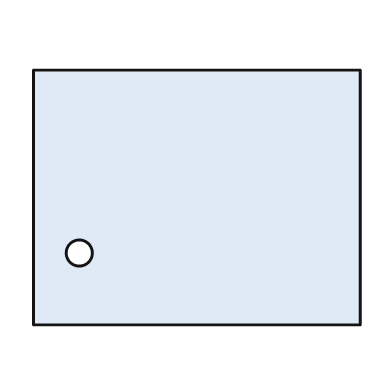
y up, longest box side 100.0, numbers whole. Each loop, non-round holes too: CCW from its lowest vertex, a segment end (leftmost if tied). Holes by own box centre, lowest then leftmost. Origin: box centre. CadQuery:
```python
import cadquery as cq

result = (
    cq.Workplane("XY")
    .moveTo(-50.0, -39.0)
    .lineTo(50.0, -39.0)
    .lineTo(50.0, 39.0)
    .lineTo(-50.0, 39.0)
    .close()
    .moveTo(-36.0, -17.0)
    .circle(4.0)
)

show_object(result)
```